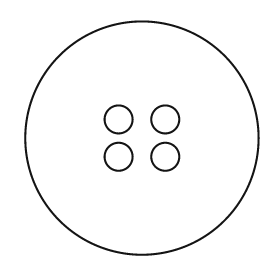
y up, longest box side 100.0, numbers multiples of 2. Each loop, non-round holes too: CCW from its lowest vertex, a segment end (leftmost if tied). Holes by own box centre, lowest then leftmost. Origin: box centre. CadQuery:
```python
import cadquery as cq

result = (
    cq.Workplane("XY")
    .moveTo(0.0, 0.0)
    .circle(50.0)
    .moveTo(-10.0, -8.0)
    .circle(6.0)
    .moveTo(10.0, -8.0)
    .circle(6.0)
    .moveTo(-10.0, 8.0)
    .circle(6.0)
    .moveTo(10.0, 8.0)
    .circle(6.0)
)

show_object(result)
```